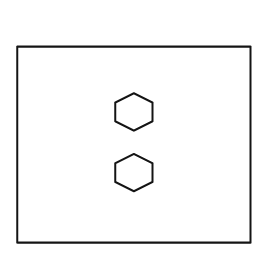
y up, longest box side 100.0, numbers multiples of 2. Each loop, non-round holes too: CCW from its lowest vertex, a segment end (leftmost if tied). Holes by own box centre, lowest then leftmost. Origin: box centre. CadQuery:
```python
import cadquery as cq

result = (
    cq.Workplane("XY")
    .moveTo(-50.0, -42.0)
    .lineTo(50.0, -42.0)
    .lineTo(50.0, 42.0)
    .lineTo(-50.0, 42.0)
    .close()
    .moveTo(0.0, -20.0)
    .lineTo(8.0, -16.0)
    .lineTo(8.0, -8.0)
    .lineTo(0.0, -4.0)
    .lineTo(-8.0, -8.0)
    .lineTo(-8.0, -16.0)
    .close()
    .moveTo(0.0, 6.0)
    .lineTo(8.0, 10.0)
    .lineTo(8.0, 18.0)
    .lineTo(0.0, 22.0)
    .lineTo(-8.0, 18.0)
    .lineTo(-8.0, 10.0)
    .close()
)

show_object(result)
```